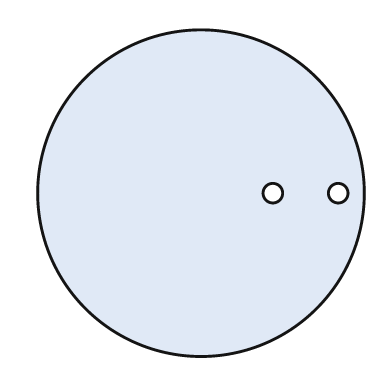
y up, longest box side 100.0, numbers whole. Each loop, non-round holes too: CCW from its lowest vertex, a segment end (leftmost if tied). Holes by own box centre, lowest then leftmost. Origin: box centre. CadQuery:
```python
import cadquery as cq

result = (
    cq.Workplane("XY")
    .moveTo(0.0, 0.0)
    .circle(50.0)
    .moveTo(22.0, 0.0)
    .circle(3.0)
    .moveTo(42.0, 0.0)
    .circle(3.0)
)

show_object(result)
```